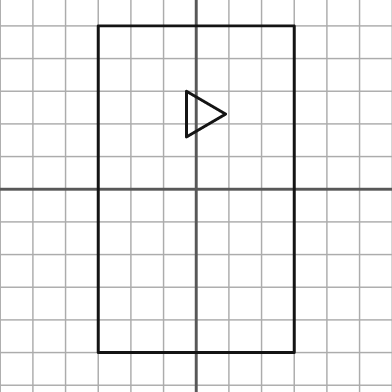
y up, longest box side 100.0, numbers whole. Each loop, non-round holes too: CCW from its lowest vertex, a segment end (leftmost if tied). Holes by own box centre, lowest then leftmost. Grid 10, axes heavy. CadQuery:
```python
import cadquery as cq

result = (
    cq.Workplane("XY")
    .moveTo(-30.0, -50.0)
    .lineTo(30.0, -50.0)
    .lineTo(30.0, 50.0)
    .lineTo(-30.0, 50.0)
    .close()
    .moveTo(-3.0, 16.0)
    .lineTo(9.0, 23.0)
    .lineTo(-3.0, 30.0)
    .close()
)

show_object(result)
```